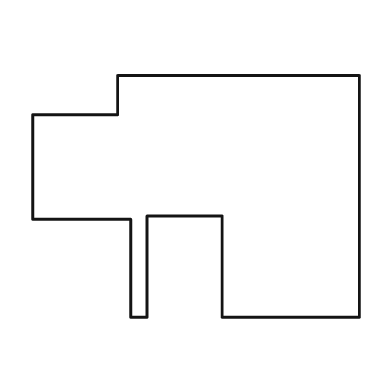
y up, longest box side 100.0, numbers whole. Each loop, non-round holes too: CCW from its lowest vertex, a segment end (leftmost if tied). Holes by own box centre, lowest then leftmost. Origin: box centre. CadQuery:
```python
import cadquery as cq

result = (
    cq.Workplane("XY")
    .moveTo(-20.0, -37.0)
    .lineTo(-15.0, -37.0)
    .lineTo(-15.0, -6.0)
    .lineTo(8.0, -6.0)
    .lineTo(8.0, -37.0)
    .lineTo(50.0, -37.0)
    .lineTo(50.0, 37.0)
    .lineTo(-24.0, 37.0)
    .lineTo(-24.0, 25.0)
    .lineTo(-50.0, 25.0)
    .lineTo(-50.0, -7.0)
    .lineTo(-20.0, -7.0)
    .close()
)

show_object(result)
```